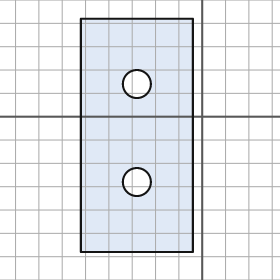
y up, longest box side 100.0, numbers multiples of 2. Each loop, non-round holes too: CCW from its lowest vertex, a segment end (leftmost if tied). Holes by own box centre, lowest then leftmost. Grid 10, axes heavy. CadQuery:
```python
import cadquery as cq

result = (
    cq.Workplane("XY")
    .moveTo(-52.0, -58.0)
    .lineTo(-4.0, -58.0)
    .lineTo(-4.0, 42.0)
    .lineTo(-52.0, 42.0)
    .close()
    .moveTo(-28.0, -28.0)
    .circle(6.0)
    .moveTo(-28.0, 14.0)
    .circle(6.0)
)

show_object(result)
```